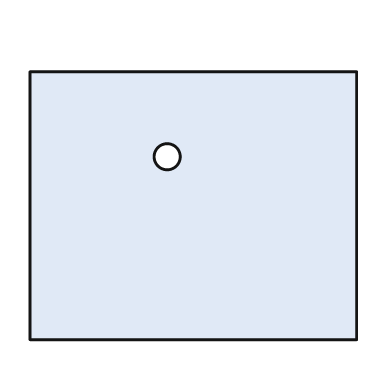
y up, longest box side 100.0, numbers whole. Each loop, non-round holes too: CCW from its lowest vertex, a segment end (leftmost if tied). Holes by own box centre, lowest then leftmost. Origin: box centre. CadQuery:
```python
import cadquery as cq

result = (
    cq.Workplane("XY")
    .moveTo(-50.0, -41.0)
    .lineTo(50.0, -41.0)
    .lineTo(50.0, 41.0)
    .lineTo(-50.0, 41.0)
    .close()
    .moveTo(-8.0, 15.0)
    .circle(4.0)
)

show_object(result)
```